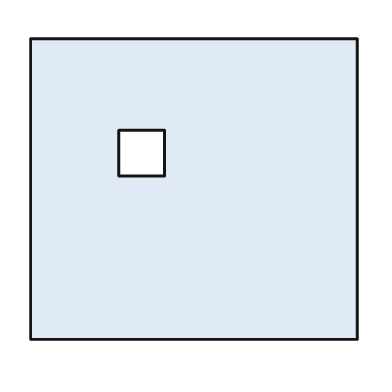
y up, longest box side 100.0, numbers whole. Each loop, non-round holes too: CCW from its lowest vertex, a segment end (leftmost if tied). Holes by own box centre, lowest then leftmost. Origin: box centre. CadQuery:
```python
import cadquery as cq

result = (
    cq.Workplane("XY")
    .moveTo(-50.0, -46.0)
    .lineTo(50.0, -46.0)
    .lineTo(50.0, 46.0)
    .lineTo(-50.0, 46.0)
    .close()
    .moveTo(-23.0, 4.0)
    .lineTo(-9.0, 4.0)
    .lineTo(-9.0, 18.0)
    .lineTo(-23.0, 18.0)
    .close()
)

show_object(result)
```